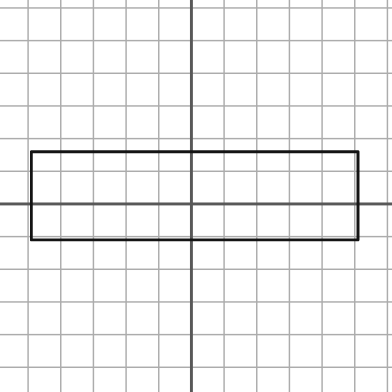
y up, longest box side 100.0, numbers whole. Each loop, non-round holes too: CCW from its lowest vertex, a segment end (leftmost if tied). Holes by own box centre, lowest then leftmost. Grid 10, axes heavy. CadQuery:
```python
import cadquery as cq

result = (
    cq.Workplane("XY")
    .moveTo(-49.0, -11.0)
    .lineTo(51.0, -11.0)
    .lineTo(51.0, 16.0)
    .lineTo(-49.0, 16.0)
    .close()
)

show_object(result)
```